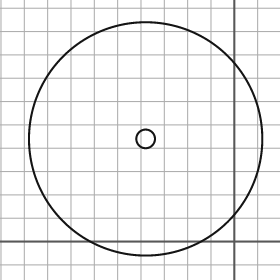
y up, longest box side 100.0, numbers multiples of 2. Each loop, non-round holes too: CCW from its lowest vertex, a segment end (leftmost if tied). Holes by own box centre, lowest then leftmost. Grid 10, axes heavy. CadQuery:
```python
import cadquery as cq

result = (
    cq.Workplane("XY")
    .moveTo(-38.0, 44.0)
    .circle(50.0)
    .moveTo(-38.0, 44.0)
    .circle(4.0)
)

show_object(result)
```